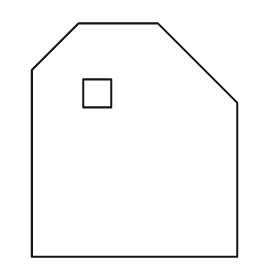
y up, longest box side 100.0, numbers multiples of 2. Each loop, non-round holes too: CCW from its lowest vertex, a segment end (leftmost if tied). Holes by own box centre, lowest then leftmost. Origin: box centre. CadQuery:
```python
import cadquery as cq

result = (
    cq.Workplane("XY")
    .moveTo(-44.0, -50.0)
    .lineTo(44.0, -50.0)
    .lineTo(44.0, 16.0)
    .lineTo(10.0, 50.0)
    .lineTo(-24.0, 50.0)
    .lineTo(-44.0, 30.0)
    .close()
    .moveTo(-22.0, 14.0)
    .lineTo(-10.0, 14.0)
    .lineTo(-10.0, 26.0)
    .lineTo(-22.0, 26.0)
    .close()
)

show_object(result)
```